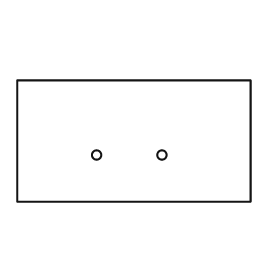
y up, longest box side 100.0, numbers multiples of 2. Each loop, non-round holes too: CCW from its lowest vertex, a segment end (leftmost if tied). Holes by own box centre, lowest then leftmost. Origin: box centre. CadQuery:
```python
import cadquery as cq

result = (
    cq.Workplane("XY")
    .moveTo(-50.0, -26.0)
    .lineTo(50.0, -26.0)
    .lineTo(50.0, 26.0)
    .lineTo(-50.0, 26.0)
    .close()
    .moveTo(-16.0, -6.0)
    .circle(2.0)
    .moveTo(12.0, -6.0)
    .circle(2.0)
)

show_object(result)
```